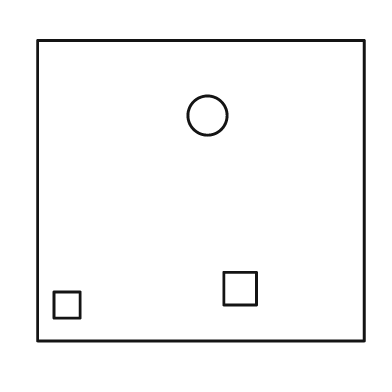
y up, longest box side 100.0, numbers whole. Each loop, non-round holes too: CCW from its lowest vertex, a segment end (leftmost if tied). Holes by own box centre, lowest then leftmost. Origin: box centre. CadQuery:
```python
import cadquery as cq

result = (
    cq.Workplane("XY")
    .moveTo(-50.0, -46.0)
    .lineTo(50.0, -46.0)
    .lineTo(50.0, 46.0)
    .lineTo(-50.0, 46.0)
    .close()
    .moveTo(-45.0, -39.0)
    .lineTo(-37.0, -39.0)
    .lineTo(-37.0, -31.0)
    .lineTo(-45.0, -31.0)
    .close()
    .moveTo(7.0, -35.0)
    .lineTo(17.0, -35.0)
    .lineTo(17.0, -25.0)
    .lineTo(7.0, -25.0)
    .close()
    .moveTo(2.0, 23.0)
    .circle(6.0)
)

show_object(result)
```